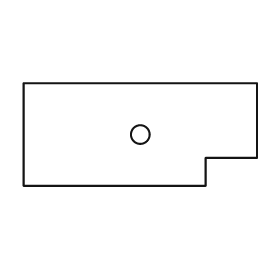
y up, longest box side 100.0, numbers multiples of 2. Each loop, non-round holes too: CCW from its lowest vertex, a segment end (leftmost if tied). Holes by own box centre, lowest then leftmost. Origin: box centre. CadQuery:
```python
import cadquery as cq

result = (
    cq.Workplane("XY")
    .moveTo(-50.0, -22.0)
    .lineTo(28.0, -22.0)
    .lineTo(28.0, -10.0)
    .lineTo(50.0, -10.0)
    .lineTo(50.0, 22.0)
    .lineTo(-50.0, 22.0)
    .close()
    .moveTo(0.0, 0.0)
    .circle(4.0)
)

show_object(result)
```